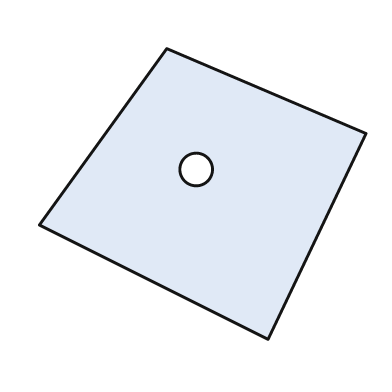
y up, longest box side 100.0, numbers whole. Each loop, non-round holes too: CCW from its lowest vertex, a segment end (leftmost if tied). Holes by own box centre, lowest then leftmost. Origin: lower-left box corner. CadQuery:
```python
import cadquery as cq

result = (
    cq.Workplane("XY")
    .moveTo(70.0, 0.0)
    .lineTo(100.0, 63.0)
    .lineTo(39.0, 89.0)
    .lineTo(0.0, 35.0)
    .close()
    .moveTo(48.0, 52.0)
    .circle(5.0)
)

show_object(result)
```